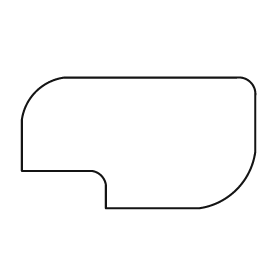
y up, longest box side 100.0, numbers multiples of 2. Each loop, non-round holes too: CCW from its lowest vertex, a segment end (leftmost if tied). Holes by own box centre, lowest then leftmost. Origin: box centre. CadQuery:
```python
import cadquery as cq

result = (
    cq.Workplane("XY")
    .moveTo(-14.0, -28.0)
    .lineTo(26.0, -28.0)
    .threePointArc((42.0, -20.0), (50.0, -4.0))
    .lineTo(50.0, 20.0)
    .threePointArc((48.0, 26.0), (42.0, 28.0))
    .lineTo(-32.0, 28.0)
    .threePointArc((-44.0, 22.0), (-50.0, 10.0))
    .lineTo(-50.0, -12.0)
    .lineTo(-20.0, -12.0)
    .threePointArc((-16.0, -14.0), (-14.0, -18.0))
    .close()
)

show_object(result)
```